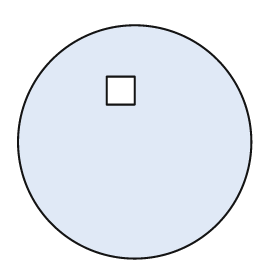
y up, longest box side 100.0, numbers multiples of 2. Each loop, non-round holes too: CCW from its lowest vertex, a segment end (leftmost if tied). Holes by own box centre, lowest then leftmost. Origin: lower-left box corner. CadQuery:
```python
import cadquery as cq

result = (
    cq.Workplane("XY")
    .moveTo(50.0, 50.0)
    .circle(50.0)
    .moveTo(38.0, 66.0)
    .lineTo(50.0, 66.0)
    .lineTo(50.0, 78.0)
    .lineTo(38.0, 78.0)
    .close()
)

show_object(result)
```